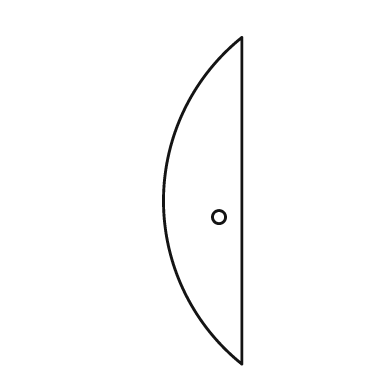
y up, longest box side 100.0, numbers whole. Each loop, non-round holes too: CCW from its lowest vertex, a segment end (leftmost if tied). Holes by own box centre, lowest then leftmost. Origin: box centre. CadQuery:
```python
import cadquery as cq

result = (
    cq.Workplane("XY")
    .moveTo(12.0, -50.0)
    .lineTo(12.0, 50.0)
    .threePointArc((-12.0, 0.0), (12.0, -50.0))
    .close()
    .moveTo(5.0, -5.0)
    .circle(2.0)
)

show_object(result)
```